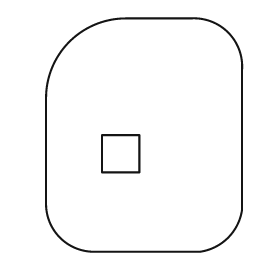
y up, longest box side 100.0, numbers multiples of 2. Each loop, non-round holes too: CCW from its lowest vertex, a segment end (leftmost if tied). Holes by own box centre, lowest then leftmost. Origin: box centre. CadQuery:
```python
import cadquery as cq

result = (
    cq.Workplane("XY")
    .moveTo(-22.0, -50.0)
    .lineTo(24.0, -50.0)
    .threePointArc((36.0, -44.0), (42.0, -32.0))
    .lineTo(42.0, 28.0)
    .threePointArc((36.0, 44.0), (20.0, 50.0))
    .lineTo(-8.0, 50.0)
    .threePointArc((-32.0, 40.0), (-42.0, 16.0))
    .lineTo(-42.0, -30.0)
    .threePointArc((-36.0, -44.0), (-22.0, -50.0))
    .close()
    .moveTo(-18.0, -16.0)
    .lineTo(-2.0, -16.0)
    .lineTo(-2.0, 0.0)
    .lineTo(-18.0, 0.0)
    .close()
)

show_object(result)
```